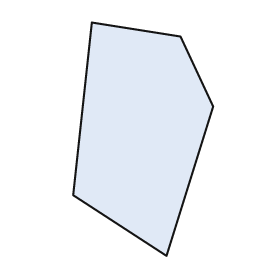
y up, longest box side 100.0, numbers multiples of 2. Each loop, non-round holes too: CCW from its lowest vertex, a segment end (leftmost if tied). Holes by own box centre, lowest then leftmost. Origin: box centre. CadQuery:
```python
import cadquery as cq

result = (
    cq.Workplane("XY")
    .moveTo(10.0, -50.0)
    .lineTo(30.0, 14.0)
    .lineTo(16.0, 44.0)
    .lineTo(-22.0, 50.0)
    .lineTo(-30.0, -24.0)
    .close()
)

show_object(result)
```